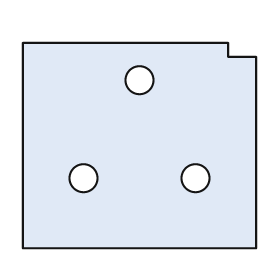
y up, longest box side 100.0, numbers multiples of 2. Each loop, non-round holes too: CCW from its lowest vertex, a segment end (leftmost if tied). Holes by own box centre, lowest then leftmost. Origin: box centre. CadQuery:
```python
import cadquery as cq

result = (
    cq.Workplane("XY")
    .moveTo(-50.0, -44.0)
    .lineTo(50.0, -44.0)
    .lineTo(50.0, 38.0)
    .lineTo(38.0, 38.0)
    .lineTo(38.0, 44.0)
    .lineTo(-50.0, 44.0)
    .close()
    .moveTo(-24.0, -14.0)
    .circle(6.0)
    .moveTo(24.0, -14.0)
    .circle(6.0)
    .moveTo(0.0, 28.0)
    .circle(6.0)
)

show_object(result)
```